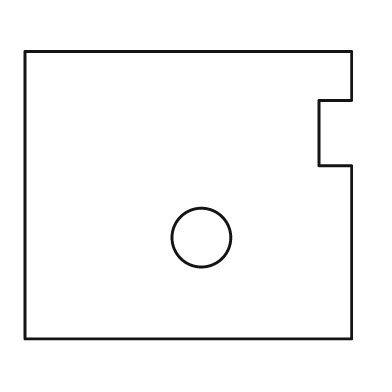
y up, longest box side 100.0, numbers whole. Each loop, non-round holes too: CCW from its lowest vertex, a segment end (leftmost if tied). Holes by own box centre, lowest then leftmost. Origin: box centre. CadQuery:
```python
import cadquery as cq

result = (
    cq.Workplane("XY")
    .moveTo(-50.0, -44.0)
    .lineTo(50.0, -44.0)
    .lineTo(50.0, 9.0)
    .lineTo(40.0, 9.0)
    .lineTo(40.0, 29.0)
    .lineTo(50.0, 29.0)
    .lineTo(50.0, 44.0)
    .lineTo(-50.0, 44.0)
    .close()
    .moveTo(4.0, -13.0)
    .circle(9.0)
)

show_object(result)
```